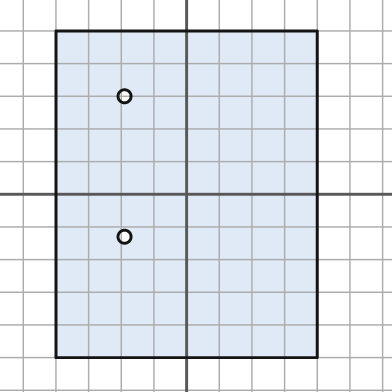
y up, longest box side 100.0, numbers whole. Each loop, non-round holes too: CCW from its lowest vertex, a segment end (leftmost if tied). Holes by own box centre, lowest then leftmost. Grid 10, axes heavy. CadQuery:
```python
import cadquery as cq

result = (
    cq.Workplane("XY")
    .moveTo(-40.0, -50.0)
    .lineTo(40.0, -50.0)
    .lineTo(40.0, 50.0)
    .lineTo(-40.0, 50.0)
    .close()
    .moveTo(-19.0, -13.0)
    .circle(2.0)
    .moveTo(-19.0, 30.0)
    .circle(2.0)
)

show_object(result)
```